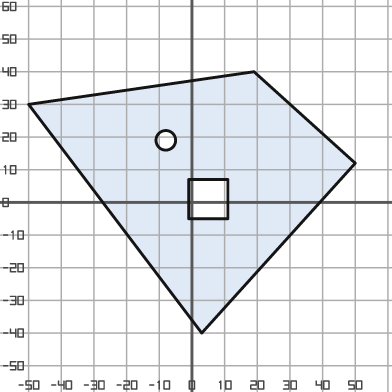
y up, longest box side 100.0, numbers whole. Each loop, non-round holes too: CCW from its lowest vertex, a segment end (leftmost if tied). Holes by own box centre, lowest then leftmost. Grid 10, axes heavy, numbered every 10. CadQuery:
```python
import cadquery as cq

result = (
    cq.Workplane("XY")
    .moveTo(3.0, -40.0)
    .lineTo(50.0, 12.0)
    .lineTo(19.0, 40.0)
    .lineTo(-50.0, 30.0)
    .close()
    .moveTo(-1.0, -5.0)
    .lineTo(11.0, -5.0)
    .lineTo(11.0, 7.0)
    .lineTo(-1.0, 7.0)
    .close()
    .moveTo(-8.0, 19.0)
    .circle(3.0)
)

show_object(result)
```